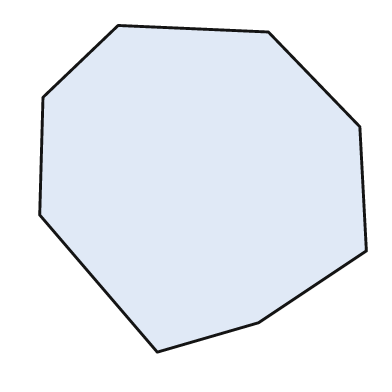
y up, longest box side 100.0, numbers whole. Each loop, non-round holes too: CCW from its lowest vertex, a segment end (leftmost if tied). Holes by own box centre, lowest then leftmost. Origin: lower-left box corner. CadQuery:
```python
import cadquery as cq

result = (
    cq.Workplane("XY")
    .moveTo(36.0, 0.0)
    .lineTo(67.0, 9.0)
    .lineTo(100.0, 31.0)
    .lineTo(98.0, 69.0)
    .lineTo(70.0, 98.0)
    .lineTo(24.0, 100.0)
    .lineTo(1.0, 78.0)
    .lineTo(0.0, 42.0)
    .close()
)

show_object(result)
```